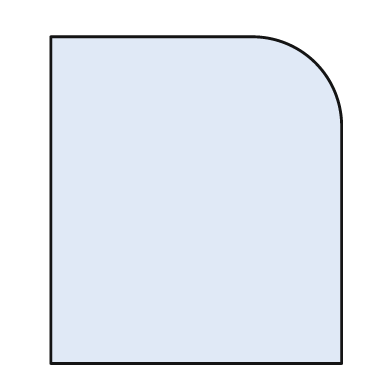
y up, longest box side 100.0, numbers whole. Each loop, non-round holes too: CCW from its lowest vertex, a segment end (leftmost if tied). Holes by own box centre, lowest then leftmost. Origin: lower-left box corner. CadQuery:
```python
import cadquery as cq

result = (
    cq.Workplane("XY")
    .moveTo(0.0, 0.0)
    .lineTo(89.0, 0.0)
    .lineTo(89.0, 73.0)
    .threePointArc((81.0, 92.0), (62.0, 100.0))
    .lineTo(0.0, 100.0)
    .close()
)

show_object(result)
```